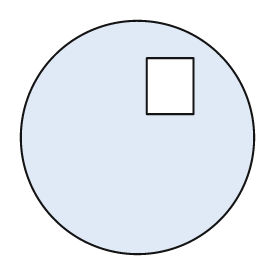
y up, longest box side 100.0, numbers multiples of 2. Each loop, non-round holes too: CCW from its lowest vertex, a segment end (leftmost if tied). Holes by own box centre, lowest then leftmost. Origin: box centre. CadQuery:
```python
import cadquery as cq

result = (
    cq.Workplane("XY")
    .moveTo(0.0, 0.0)
    .circle(50.0)
    .moveTo(4.0, 10.0)
    .lineTo(24.0, 10.0)
    .lineTo(24.0, 34.0)
    .lineTo(4.0, 34.0)
    .close()
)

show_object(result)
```